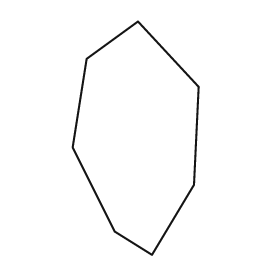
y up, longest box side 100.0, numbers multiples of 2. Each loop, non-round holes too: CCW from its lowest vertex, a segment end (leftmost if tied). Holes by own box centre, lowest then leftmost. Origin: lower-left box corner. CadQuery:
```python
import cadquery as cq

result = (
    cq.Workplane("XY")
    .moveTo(34.0, 0.0)
    .lineTo(52.0, 30.0)
    .lineTo(54.0, 72.0)
    .lineTo(28.0, 100.0)
    .lineTo(6.0, 84.0)
    .lineTo(0.0, 46.0)
    .lineTo(18.0, 10.0)
    .close()
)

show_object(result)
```